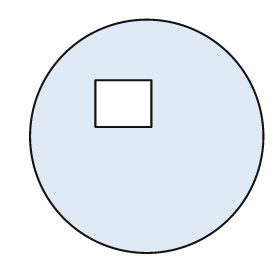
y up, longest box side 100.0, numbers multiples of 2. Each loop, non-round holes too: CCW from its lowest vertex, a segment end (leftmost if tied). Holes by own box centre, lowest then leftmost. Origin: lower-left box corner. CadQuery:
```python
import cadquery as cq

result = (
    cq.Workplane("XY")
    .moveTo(50.0, 50.0)
    .circle(50.0)
    .moveTo(28.0, 54.0)
    .lineTo(52.0, 54.0)
    .lineTo(52.0, 74.0)
    .lineTo(28.0, 74.0)
    .close()
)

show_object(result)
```